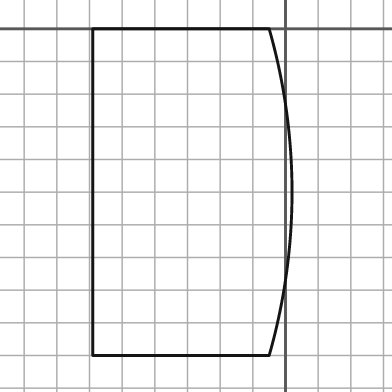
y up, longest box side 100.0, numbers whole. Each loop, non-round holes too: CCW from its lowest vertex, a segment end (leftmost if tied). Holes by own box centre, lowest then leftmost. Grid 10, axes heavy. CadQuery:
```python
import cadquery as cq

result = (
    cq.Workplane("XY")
    .moveTo(-59.0, -100.0)
    .lineTo(-5.0, -100.0)
    .threePointArc((2.0, -50.0), (-5.0, 0.0))
    .lineTo(-59.0, 0.0)
    .close()
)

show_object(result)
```